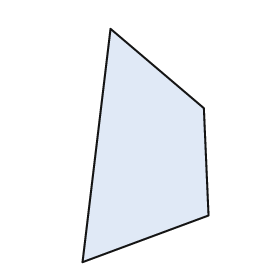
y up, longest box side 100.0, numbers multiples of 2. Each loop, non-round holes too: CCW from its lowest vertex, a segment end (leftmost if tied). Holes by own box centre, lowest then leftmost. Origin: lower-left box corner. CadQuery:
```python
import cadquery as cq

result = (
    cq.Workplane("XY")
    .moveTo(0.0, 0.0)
    .lineTo(54.0, 20.0)
    .lineTo(52.0, 66.0)
    .lineTo(12.0, 100.0)
    .close()
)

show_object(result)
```